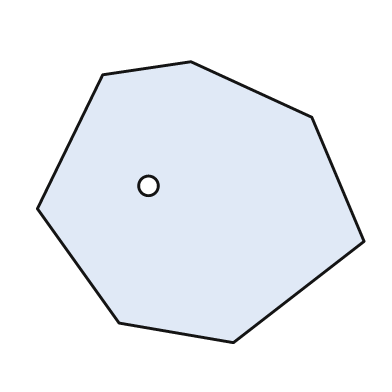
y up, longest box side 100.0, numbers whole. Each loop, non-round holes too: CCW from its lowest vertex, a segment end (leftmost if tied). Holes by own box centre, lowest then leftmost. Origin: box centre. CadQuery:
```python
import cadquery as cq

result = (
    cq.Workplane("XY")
    .moveTo(10.0, -43.0)
    .lineTo(50.0, -12.0)
    .lineTo(34.0, 26.0)
    .lineTo(-3.0, 43.0)
    .lineTo(-30.0, 39.0)
    .lineTo(-50.0, -2.0)
    .lineTo(-25.0, -37.0)
    .close()
    .moveTo(-16.0, 5.0)
    .circle(3.0)
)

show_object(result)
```